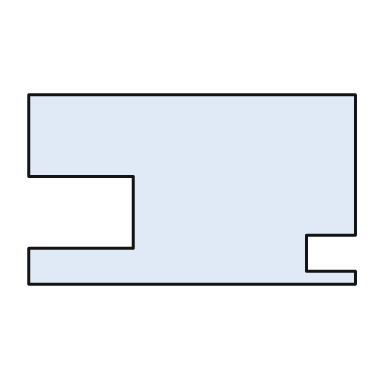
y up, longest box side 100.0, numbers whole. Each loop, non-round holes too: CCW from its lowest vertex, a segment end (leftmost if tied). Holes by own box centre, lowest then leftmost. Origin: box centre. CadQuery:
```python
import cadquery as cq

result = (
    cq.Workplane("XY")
    .moveTo(-50.0, -29.0)
    .lineTo(50.0, -29.0)
    .lineTo(50.0, -25.0)
    .lineTo(35.0, -25.0)
    .lineTo(35.0, -14.0)
    .lineTo(50.0, -14.0)
    .lineTo(50.0, 29.0)
    .lineTo(-50.0, 29.0)
    .lineTo(-50.0, 4.0)
    .lineTo(-18.0, 4.0)
    .lineTo(-18.0, -18.0)
    .lineTo(-50.0, -18.0)
    .close()
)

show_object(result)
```